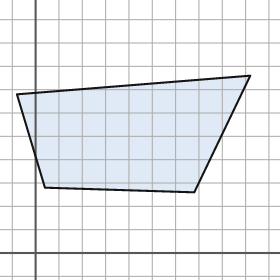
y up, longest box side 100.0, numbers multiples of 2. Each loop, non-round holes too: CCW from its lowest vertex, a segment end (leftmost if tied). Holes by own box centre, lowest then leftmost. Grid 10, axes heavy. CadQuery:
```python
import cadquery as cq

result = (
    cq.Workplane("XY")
    .moveTo(68.0, 26.0)
    .lineTo(92.0, 76.0)
    .lineTo(-8.0, 68.0)
    .lineTo(4.0, 28.0)
    .close()
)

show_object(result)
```